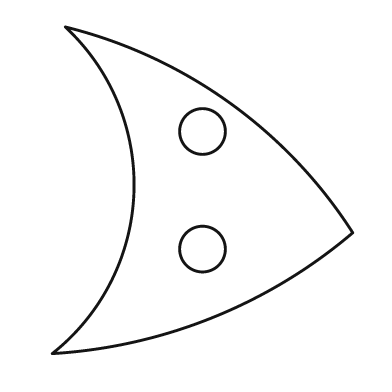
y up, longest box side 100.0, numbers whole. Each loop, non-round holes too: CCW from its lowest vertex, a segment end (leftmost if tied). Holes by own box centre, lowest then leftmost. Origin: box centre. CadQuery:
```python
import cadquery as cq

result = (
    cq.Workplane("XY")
    .moveTo(-46.0, -50.0)
    .threePointArc((3.0, -39.0), (46.0, -13.0))
    .threePointArc((8.0, 27.0), (-42.0, 50.0))
    .threePointArc((-21.0, -1.0), (-46.0, -50.0))
    .close()
    .moveTo(0.0, -18.0)
    .circle(7.0)
    .moveTo(0.0, 18.0)
    .circle(7.0)
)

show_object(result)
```